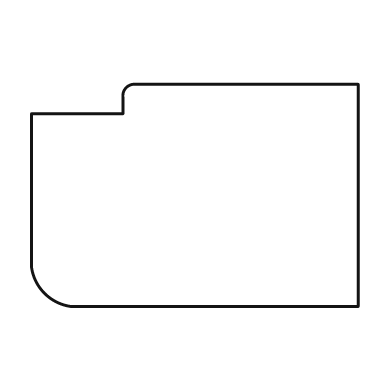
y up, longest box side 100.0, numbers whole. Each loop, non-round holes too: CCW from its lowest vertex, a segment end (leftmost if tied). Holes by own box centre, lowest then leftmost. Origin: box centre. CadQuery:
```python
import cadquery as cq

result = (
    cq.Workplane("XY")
    .moveTo(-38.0, -34.0)
    .lineTo(50.0, -34.0)
    .lineTo(50.0, 34.0)
    .lineTo(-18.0, 34.0)
    .threePointArc((-21.0, 33.0), (-22.0, 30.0))
    .lineTo(-22.0, 25.0)
    .lineTo(-50.0, 25.0)
    .lineTo(-50.0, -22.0)
    .threePointArc((-46.0, -30.0), (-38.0, -34.0))
    .close()
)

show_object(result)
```